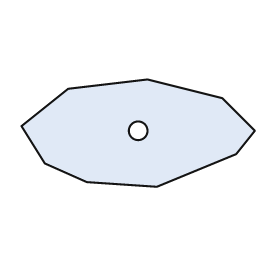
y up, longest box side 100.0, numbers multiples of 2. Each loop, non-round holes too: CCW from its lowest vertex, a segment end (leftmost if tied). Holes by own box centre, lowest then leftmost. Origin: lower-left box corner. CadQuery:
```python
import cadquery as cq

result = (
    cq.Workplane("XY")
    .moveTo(58.0, 0.0)
    .lineTo(92.0, 14.0)
    .lineTo(100.0, 24.0)
    .lineTo(86.0, 38.0)
    .lineTo(54.0, 46.0)
    .lineTo(20.0, 42.0)
    .lineTo(0.0, 26.0)
    .lineTo(10.0, 10.0)
    .lineTo(28.0, 2.0)
    .close()
    .moveTo(50.0, 24.0)
    .circle(4.0)
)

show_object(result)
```